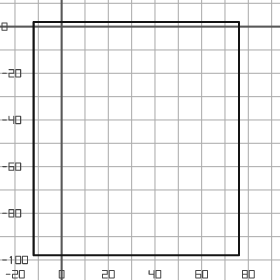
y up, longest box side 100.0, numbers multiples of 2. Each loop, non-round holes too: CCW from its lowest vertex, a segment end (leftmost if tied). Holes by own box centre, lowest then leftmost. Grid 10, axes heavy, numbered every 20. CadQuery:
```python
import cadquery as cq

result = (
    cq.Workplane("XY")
    .moveTo(-12.0, -98.0)
    .lineTo(76.0, -98.0)
    .lineTo(76.0, 2.0)
    .lineTo(-12.0, 2.0)
    .close()
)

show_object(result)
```